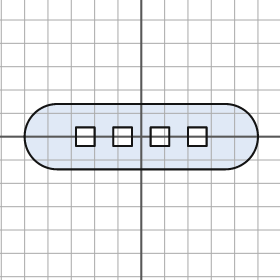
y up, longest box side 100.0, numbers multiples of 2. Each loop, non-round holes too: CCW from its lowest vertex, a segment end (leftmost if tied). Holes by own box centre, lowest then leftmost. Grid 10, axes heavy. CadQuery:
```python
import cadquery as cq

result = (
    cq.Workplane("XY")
    .moveTo(-36.0, -14.0)
    .lineTo(36.0, -14.0)
    .threePointArc((50.0, 0.0), (36.0, 14.0))
    .lineTo(-36.0, 14.0)
    .threePointArc((-50.0, 0.0), (-36.0, -14.0))
    .close()
    .moveTo(-28.0, -4.0)
    .lineTo(-20.0, -4.0)
    .lineTo(-20.0, 4.0)
    .lineTo(-28.0, 4.0)
    .close()
    .moveTo(-12.0, -4.0)
    .lineTo(-4.0, -4.0)
    .lineTo(-4.0, 4.0)
    .lineTo(-12.0, 4.0)
    .close()
    .moveTo(4.0, -4.0)
    .lineTo(12.0, -4.0)
    .lineTo(12.0, 4.0)
    .lineTo(4.0, 4.0)
    .close()
    .moveTo(20.0, -4.0)
    .lineTo(28.0, -4.0)
    .lineTo(28.0, 4.0)
    .lineTo(20.0, 4.0)
    .close()
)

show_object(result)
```